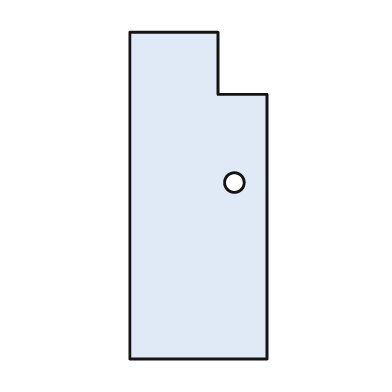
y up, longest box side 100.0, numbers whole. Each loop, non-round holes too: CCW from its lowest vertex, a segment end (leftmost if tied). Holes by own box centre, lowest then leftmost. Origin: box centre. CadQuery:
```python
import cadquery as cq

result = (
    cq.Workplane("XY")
    .moveTo(-21.0, -50.0)
    .lineTo(21.0, -50.0)
    .lineTo(21.0, 31.0)
    .lineTo(6.0, 31.0)
    .lineTo(6.0, 50.0)
    .lineTo(-21.0, 50.0)
    .close()
    .moveTo(11.0, 4.0)
    .circle(3.0)
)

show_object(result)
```